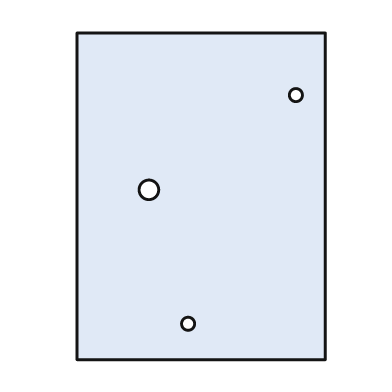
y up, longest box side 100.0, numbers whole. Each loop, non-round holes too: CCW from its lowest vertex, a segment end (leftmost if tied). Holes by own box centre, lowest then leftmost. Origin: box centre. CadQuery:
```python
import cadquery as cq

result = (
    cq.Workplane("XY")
    .moveTo(-38.0, -50.0)
    .lineTo(38.0, -50.0)
    .lineTo(38.0, 50.0)
    .lineTo(-38.0, 50.0)
    .close()
    .moveTo(-4.0, -39.0)
    .circle(2.0)
    .moveTo(-16.0, 2.0)
    .circle(3.0)
    .moveTo(29.0, 31.0)
    .circle(2.0)
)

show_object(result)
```